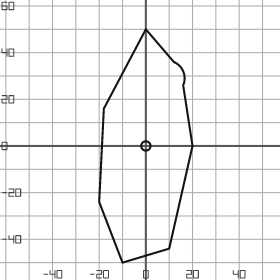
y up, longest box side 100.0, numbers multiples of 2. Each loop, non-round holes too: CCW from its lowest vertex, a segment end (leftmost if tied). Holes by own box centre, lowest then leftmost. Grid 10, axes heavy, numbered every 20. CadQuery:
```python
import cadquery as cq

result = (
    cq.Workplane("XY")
    .moveTo(-10.0, -50.0)
    .lineTo(10.0, -44.0)
    .lineTo(20.0, 0.0)
    .lineTo(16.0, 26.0)
    .threePointArc((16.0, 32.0), (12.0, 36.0))
    .lineTo(0.0, 50.0)
    .lineTo(-18.0, 16.0)
    .lineTo(-20.0, -24.0)
    .close()
    .moveTo(0.0, 0.0)
    .circle(2.0)
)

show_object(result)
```